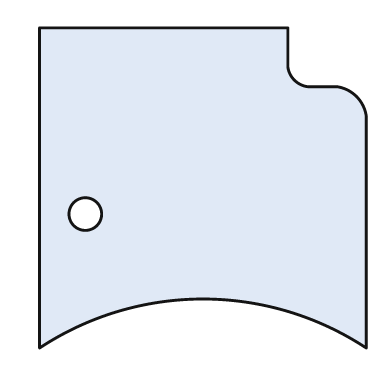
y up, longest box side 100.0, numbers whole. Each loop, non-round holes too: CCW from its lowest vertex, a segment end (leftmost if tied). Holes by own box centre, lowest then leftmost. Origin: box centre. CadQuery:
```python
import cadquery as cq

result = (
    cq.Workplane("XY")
    .moveTo(-50.0, -49.0)
    .threePointArc((0.0, -34.0), (50.0, -49.0))
    .lineTo(50.0, 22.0)
    .threePointArc((47.0, 28.0), (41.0, 31.0))
    .lineTo(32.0, 31.0)
    .threePointArc((28.0, 33.0), (26.0, 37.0))
    .lineTo(26.0, 49.0)
    .lineTo(-50.0, 49.0)
    .close()
    .moveTo(-36.0, -8.0)
    .circle(5.0)
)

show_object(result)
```